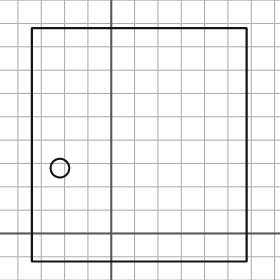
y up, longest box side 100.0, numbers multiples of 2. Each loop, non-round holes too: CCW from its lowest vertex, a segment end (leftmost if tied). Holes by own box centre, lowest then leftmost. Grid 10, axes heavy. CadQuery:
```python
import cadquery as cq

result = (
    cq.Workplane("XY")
    .moveTo(-34.0, -12.0)
    .lineTo(58.0, -12.0)
    .lineTo(58.0, 88.0)
    .lineTo(-34.0, 88.0)
    .close()
    .moveTo(-22.0, 28.0)
    .circle(4.0)
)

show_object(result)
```